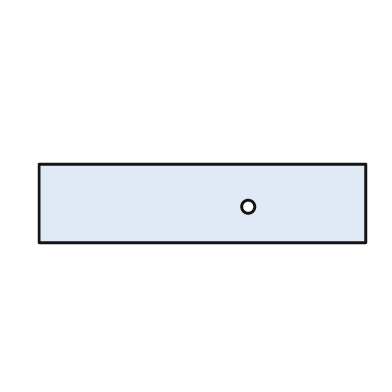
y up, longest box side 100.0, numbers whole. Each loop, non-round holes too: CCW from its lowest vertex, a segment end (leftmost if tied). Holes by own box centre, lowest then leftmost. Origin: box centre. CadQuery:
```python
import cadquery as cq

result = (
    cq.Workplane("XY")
    .moveTo(-50.0, -12.0)
    .lineTo(50.0, -12.0)
    .lineTo(50.0, 12.0)
    .lineTo(-50.0, 12.0)
    .close()
    .moveTo(14.0, -1.0)
    .circle(2.0)
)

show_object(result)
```